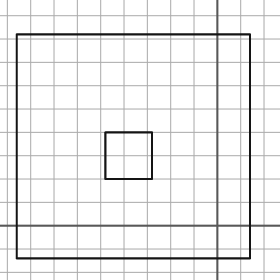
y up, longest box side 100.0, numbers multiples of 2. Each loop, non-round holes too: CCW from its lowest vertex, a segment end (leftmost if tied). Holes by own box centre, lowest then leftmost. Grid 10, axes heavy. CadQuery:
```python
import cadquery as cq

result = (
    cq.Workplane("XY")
    .moveTo(-86.0, -14.0)
    .lineTo(14.0, -14.0)
    .lineTo(14.0, 82.0)
    .lineTo(-86.0, 82.0)
    .close()
    .moveTo(-48.0, 20.0)
    .lineTo(-28.0, 20.0)
    .lineTo(-28.0, 40.0)
    .lineTo(-48.0, 40.0)
    .close()
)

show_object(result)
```